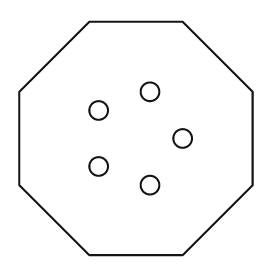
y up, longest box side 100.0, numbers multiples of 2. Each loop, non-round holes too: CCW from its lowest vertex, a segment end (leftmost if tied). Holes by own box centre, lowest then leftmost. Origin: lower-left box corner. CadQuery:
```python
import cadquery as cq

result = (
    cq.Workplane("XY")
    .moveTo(30.0, 0.0)
    .lineTo(70.0, 0.0)
    .lineTo(100.0, 30.0)
    .lineTo(100.0, 70.0)
    .lineTo(70.0, 100.0)
    .lineTo(30.0, 100.0)
    .lineTo(0.0, 70.0)
    .lineTo(0.0, 30.0)
    .close()
    .moveTo(56.0, 30.0)
    .circle(4.0)
    .moveTo(34.0, 38.0)
    .circle(4.0)
    .moveTo(70.0, 50.0)
    .circle(4.0)
    .moveTo(34.0, 62.0)
    .circle(4.0)
    .moveTo(56.0, 70.0)
    .circle(4.0)
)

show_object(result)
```